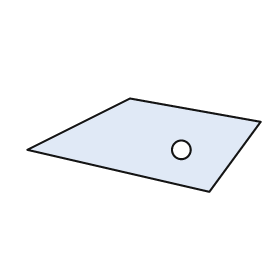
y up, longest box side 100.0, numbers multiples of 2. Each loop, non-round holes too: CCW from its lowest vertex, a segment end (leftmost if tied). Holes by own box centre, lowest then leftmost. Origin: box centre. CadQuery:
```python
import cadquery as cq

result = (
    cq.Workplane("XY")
    .moveTo(28.0, -20.0)
    .lineTo(50.0, 10.0)
    .lineTo(-6.0, 20.0)
    .lineTo(-50.0, -2.0)
    .close()
    .moveTo(16.0, -2.0)
    .circle(4.0)
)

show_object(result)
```